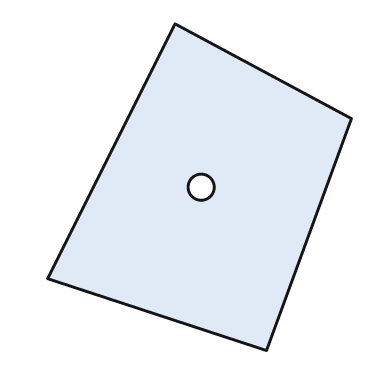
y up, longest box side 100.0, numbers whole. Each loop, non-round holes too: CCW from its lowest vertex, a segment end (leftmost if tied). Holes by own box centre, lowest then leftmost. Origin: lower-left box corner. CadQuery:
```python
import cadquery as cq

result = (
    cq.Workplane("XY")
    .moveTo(67.0, 0.0)
    .lineTo(93.0, 71.0)
    .lineTo(39.0, 100.0)
    .lineTo(0.0, 22.0)
    .close()
    .moveTo(47.0, 50.0)
    .circle(4.0)
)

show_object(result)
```